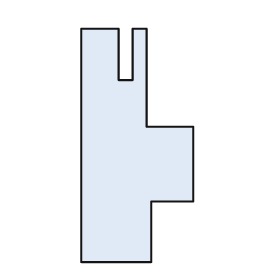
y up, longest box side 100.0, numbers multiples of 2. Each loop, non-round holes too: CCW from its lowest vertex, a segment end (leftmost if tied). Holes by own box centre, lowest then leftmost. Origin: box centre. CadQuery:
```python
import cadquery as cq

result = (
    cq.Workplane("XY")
    .moveTo(-24.0, -50.0)
    .lineTo(6.0, -50.0)
    .lineTo(6.0, -24.0)
    .lineTo(24.0, -24.0)
    .lineTo(24.0, 8.0)
    .lineTo(4.0, 8.0)
    .lineTo(4.0, 50.0)
    .lineTo(-2.0, 50.0)
    .lineTo(-2.0, 28.0)
    .lineTo(-8.0, 28.0)
    .lineTo(-8.0, 50.0)
    .lineTo(-24.0, 50.0)
    .close()
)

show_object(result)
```